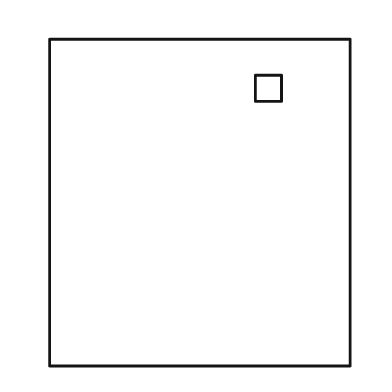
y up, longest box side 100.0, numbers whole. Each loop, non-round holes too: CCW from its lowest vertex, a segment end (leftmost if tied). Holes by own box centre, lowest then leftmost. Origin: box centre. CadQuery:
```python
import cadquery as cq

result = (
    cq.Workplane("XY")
    .moveTo(-46.0, -50.0)
    .lineTo(46.0, -50.0)
    .lineTo(46.0, 50.0)
    .lineTo(-46.0, 50.0)
    .close()
    .moveTo(17.0, 31.0)
    .lineTo(25.0, 31.0)
    .lineTo(25.0, 39.0)
    .lineTo(17.0, 39.0)
    .close()
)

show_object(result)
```